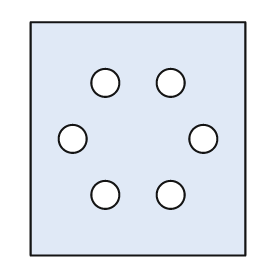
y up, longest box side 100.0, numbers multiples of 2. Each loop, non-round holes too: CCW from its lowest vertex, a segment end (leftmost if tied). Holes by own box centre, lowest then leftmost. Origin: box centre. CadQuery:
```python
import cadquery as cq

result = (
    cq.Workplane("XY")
    .moveTo(-46.0, -50.0)
    .lineTo(46.0, -50.0)
    .lineTo(46.0, 50.0)
    .lineTo(-46.0, 50.0)
    .close()
    .moveTo(-14.0, -24.0)
    .circle(6.0)
    .moveTo(14.0, -24.0)
    .circle(6.0)
    .moveTo(-28.0, 0.0)
    .circle(6.0)
    .moveTo(28.0, 0.0)
    .circle(6.0)
    .moveTo(-14.0, 24.0)
    .circle(6.0)
    .moveTo(14.0, 24.0)
    .circle(6.0)
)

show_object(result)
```